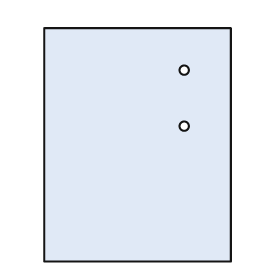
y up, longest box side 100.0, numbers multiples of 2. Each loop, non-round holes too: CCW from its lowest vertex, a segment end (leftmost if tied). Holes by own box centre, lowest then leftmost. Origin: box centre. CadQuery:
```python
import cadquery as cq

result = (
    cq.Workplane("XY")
    .moveTo(-40.0, -50.0)
    .lineTo(40.0, -50.0)
    .lineTo(40.0, 50.0)
    .lineTo(-40.0, 50.0)
    .close()
    .moveTo(20.0, 8.0)
    .circle(2.0)
    .moveTo(20.0, 32.0)
    .circle(2.0)
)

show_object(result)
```